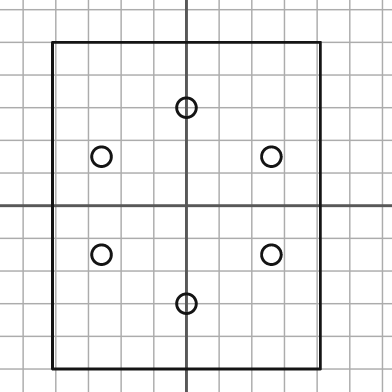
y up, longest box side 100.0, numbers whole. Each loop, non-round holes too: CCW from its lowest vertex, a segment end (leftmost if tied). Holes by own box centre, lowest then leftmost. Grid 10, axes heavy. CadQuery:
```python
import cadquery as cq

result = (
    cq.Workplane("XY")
    .moveTo(-41.0, -50.0)
    .lineTo(41.0, -50.0)
    .lineTo(41.0, 50.0)
    .lineTo(-41.0, 50.0)
    .close()
    .moveTo(0.0, -30.0)
    .circle(3.0)
    .moveTo(-26.0, -15.0)
    .circle(3.0)
    .moveTo(26.0, -15.0)
    .circle(3.0)
    .moveTo(-26.0, 15.0)
    .circle(3.0)
    .moveTo(26.0, 15.0)
    .circle(3.0)
    .moveTo(0.0, 30.0)
    .circle(3.0)
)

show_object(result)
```